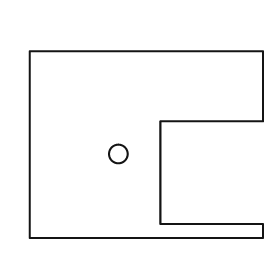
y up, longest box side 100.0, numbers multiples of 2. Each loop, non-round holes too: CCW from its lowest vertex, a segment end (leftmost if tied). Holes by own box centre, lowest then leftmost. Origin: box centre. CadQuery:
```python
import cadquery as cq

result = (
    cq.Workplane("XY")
    .moveTo(-50.0, -40.0)
    .lineTo(50.0, -40.0)
    .lineTo(50.0, -34.0)
    .lineTo(6.0, -34.0)
    .lineTo(6.0, 10.0)
    .lineTo(50.0, 10.0)
    .lineTo(50.0, 40.0)
    .lineTo(-50.0, 40.0)
    .close()
    .moveTo(-12.0, -4.0)
    .circle(4.0)
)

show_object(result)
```